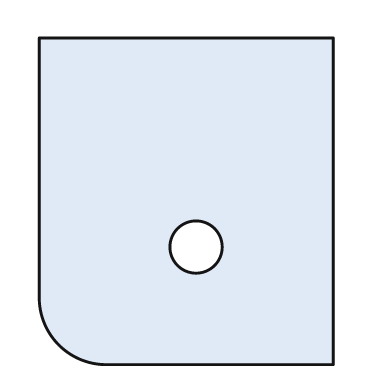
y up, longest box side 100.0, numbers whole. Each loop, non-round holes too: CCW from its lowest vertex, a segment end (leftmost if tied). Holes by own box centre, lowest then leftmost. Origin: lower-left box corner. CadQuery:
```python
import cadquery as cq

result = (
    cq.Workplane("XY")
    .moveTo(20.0, 0.0)
    .lineTo(90.0, 0.0)
    .lineTo(90.0, 100.0)
    .lineTo(0.0, 100.0)
    .lineTo(0.0, 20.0)
    .threePointArc((6.0, 6.0), (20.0, 0.0))
    .close()
    .moveTo(48.0, 36.0)
    .circle(8.0)
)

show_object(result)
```